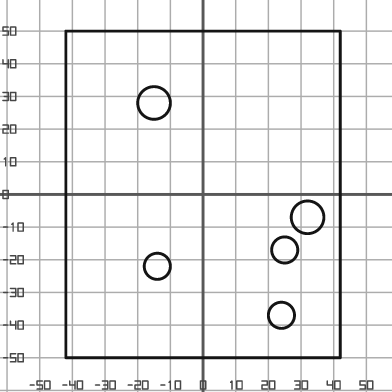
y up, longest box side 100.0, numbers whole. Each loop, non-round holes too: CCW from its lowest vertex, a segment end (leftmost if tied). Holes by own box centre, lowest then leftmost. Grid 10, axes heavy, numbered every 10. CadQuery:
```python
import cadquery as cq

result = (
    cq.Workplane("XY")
    .moveTo(-42.0, -50.0)
    .lineTo(42.0, -50.0)
    .lineTo(42.0, 50.0)
    .lineTo(-42.0, 50.0)
    .close()
    .moveTo(24.0, -37.0)
    .circle(4.0)
    .moveTo(-14.0, -22.0)
    .circle(4.0)
    .moveTo(25.0, -17.0)
    .circle(4.0)
    .moveTo(32.0, -7.0)
    .circle(5.0)
    .moveTo(-15.0, 28.0)
    .circle(5.0)
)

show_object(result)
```